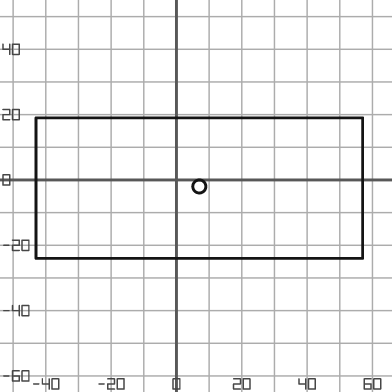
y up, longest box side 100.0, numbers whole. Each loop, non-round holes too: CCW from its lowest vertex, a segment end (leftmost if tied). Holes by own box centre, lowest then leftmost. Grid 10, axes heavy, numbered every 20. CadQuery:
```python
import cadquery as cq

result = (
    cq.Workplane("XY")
    .moveTo(-43.0, -24.0)
    .lineTo(57.0, -24.0)
    .lineTo(57.0, 19.0)
    .lineTo(-43.0, 19.0)
    .close()
    .moveTo(7.0, -2.0)
    .circle(2.0)
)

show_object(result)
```